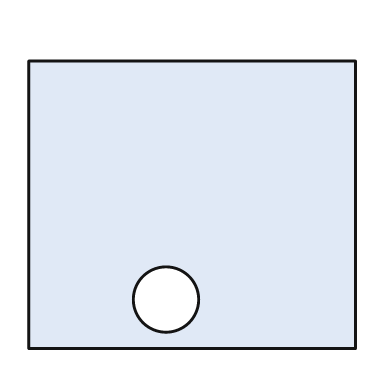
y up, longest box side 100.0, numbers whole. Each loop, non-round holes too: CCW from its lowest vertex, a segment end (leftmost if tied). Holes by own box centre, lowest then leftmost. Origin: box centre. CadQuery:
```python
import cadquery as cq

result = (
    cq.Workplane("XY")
    .moveTo(-50.0, -44.0)
    .lineTo(50.0, -44.0)
    .lineTo(50.0, 44.0)
    .lineTo(-50.0, 44.0)
    .close()
    .moveTo(-8.0, -29.0)
    .circle(10.0)
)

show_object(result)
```